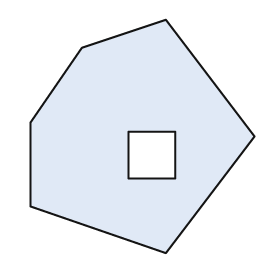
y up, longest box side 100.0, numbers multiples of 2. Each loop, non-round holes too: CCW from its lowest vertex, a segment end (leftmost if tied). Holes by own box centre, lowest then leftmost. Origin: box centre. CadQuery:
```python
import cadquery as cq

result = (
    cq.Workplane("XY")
    .moveTo(10.0, -50.0)
    .lineTo(48.0, 0.0)
    .lineTo(10.0, 50.0)
    .lineTo(-26.0, 38.0)
    .lineTo(-48.0, 6.0)
    .lineTo(-48.0, -30.0)
    .close()
    .moveTo(-6.0, -18.0)
    .lineTo(14.0, -18.0)
    .lineTo(14.0, 2.0)
    .lineTo(-6.0, 2.0)
    .close()
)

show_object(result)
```